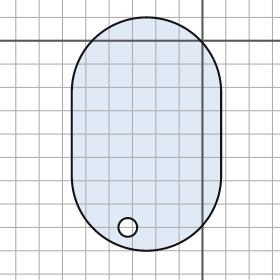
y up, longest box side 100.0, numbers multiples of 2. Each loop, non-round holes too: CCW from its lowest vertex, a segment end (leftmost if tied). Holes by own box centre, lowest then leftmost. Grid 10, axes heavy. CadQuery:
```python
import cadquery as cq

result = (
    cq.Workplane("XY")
    .moveTo(-56.0, -58.0)
    .threePointArc((-24.0, -90.0), (8.0, -58.0))
    .lineTo(8.0, -22.0)
    .threePointArc((-24.0, 10.0), (-56.0, -22.0))
    .close()
    .moveTo(-32.0, -80.0)
    .circle(4.0)
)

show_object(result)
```